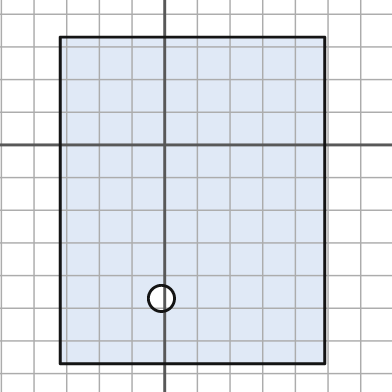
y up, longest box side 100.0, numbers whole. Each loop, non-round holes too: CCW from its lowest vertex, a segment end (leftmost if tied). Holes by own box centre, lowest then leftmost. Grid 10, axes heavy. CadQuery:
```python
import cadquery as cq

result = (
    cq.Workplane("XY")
    .moveTo(-32.0, -67.0)
    .lineTo(49.0, -67.0)
    .lineTo(49.0, 33.0)
    .lineTo(-32.0, 33.0)
    .close()
    .moveTo(-1.0, -47.0)
    .circle(4.0)
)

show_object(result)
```